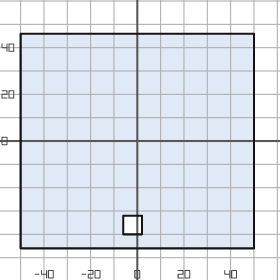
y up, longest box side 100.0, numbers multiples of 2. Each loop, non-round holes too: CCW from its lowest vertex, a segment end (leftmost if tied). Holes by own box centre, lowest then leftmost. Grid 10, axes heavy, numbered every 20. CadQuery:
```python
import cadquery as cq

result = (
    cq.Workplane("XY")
    .moveTo(-50.0, -46.0)
    .lineTo(50.0, -46.0)
    .lineTo(50.0, 46.0)
    .lineTo(-50.0, 46.0)
    .close()
    .moveTo(-6.0, -40.0)
    .lineTo(2.0, -40.0)
    .lineTo(2.0, -32.0)
    .lineTo(-6.0, -32.0)
    .close()
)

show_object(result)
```